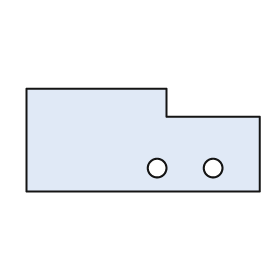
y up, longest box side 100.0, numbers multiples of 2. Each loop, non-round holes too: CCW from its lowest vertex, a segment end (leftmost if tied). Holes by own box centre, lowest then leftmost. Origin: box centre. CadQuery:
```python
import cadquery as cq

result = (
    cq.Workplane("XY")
    .moveTo(-50.0, -22.0)
    .lineTo(50.0, -22.0)
    .lineTo(50.0, 10.0)
    .lineTo(10.0, 10.0)
    .lineTo(10.0, 22.0)
    .lineTo(-50.0, 22.0)
    .close()
    .moveTo(6.0, -12.0)
    .circle(4.0)
    .moveTo(30.0, -12.0)
    .circle(4.0)
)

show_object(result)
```